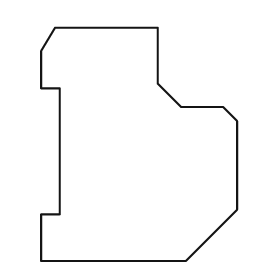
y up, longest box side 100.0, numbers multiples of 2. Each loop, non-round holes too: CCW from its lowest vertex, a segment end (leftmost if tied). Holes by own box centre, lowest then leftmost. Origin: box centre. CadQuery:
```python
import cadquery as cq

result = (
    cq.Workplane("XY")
    .moveTo(-42.0, -50.0)
    .lineTo(20.0, -50.0)
    .lineTo(42.0, -28.0)
    .lineTo(42.0, 10.0)
    .lineTo(36.0, 16.0)
    .lineTo(18.0, 16.0)
    .lineTo(8.0, 26.0)
    .lineTo(8.0, 50.0)
    .lineTo(-36.0, 50.0)
    .lineTo(-42.0, 40.0)
    .lineTo(-42.0, 24.0)
    .lineTo(-34.0, 24.0)
    .lineTo(-34.0, -30.0)
    .lineTo(-42.0, -30.0)
    .close()
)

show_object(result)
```